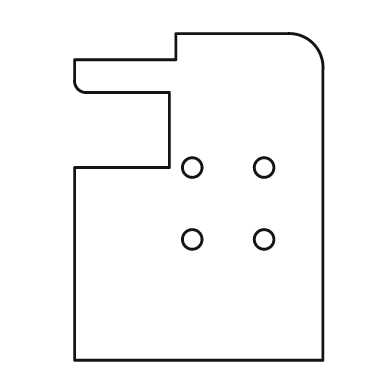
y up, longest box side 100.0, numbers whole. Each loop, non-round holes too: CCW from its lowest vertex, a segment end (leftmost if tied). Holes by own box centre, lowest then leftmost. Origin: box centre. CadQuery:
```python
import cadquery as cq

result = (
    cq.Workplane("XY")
    .moveTo(-38.0, -50.0)
    .lineTo(38.0, -50.0)
    .lineTo(38.0, 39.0)
    .threePointArc((35.0, 47.0), (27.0, 50.0))
    .lineTo(-7.0, 50.0)
    .lineTo(-7.0, 42.0)
    .lineTo(-38.0, 42.0)
    .lineTo(-38.0, 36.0)
    .threePointArc((-37.0, 33.0), (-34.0, 32.0))
    .lineTo(-9.0, 32.0)
    .lineTo(-9.0, 9.0)
    .lineTo(-38.0, 9.0)
    .close()
    .moveTo(-2.0, -13.0)
    .circle(3.0)
    .moveTo(20.0, -13.0)
    .circle(3.0)
    .moveTo(-2.0, 9.0)
    .circle(3.0)
    .moveTo(20.0, 9.0)
    .circle(3.0)
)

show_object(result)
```